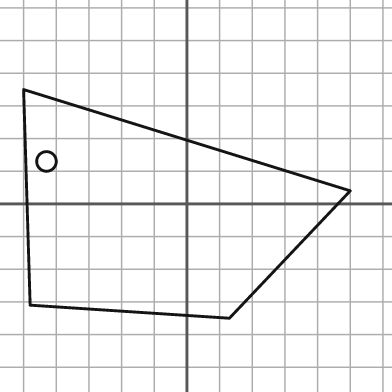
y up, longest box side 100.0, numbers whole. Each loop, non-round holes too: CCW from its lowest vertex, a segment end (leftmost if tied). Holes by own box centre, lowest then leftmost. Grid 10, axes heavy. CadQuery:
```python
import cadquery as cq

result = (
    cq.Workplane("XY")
    .moveTo(13.0, -35.0)
    .lineTo(50.0, 4.0)
    .lineTo(-50.0, 35.0)
    .lineTo(-48.0, -31.0)
    .close()
    .moveTo(-43.0, 13.0)
    .circle(3.0)
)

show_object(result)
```